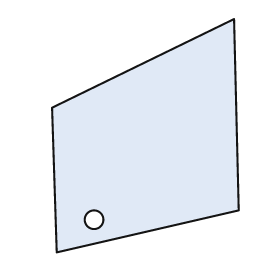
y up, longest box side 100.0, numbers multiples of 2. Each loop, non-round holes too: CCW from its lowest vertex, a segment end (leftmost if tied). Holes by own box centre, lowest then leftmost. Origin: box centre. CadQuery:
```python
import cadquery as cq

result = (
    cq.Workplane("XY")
    .moveTo(-38.0, -50.0)
    .lineTo(40.0, -32.0)
    .lineTo(38.0, 50.0)
    .lineTo(-40.0, 12.0)
    .close()
    .moveTo(-22.0, -36.0)
    .circle(4.0)
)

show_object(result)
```